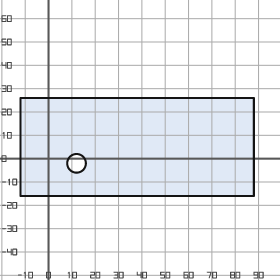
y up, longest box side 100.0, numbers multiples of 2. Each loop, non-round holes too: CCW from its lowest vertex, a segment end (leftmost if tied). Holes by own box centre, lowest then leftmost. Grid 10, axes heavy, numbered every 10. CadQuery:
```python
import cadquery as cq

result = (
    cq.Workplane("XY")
    .moveTo(-12.0, -16.0)
    .lineTo(88.0, -16.0)
    .lineTo(88.0, 26.0)
    .lineTo(-12.0, 26.0)
    .close()
    .moveTo(12.0, -2.0)
    .circle(4.0)
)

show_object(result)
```